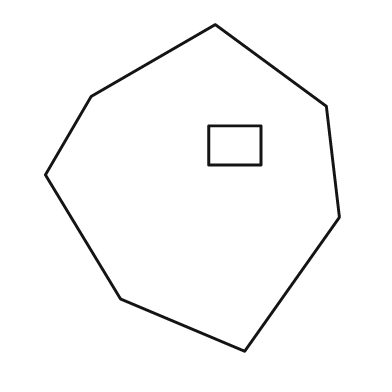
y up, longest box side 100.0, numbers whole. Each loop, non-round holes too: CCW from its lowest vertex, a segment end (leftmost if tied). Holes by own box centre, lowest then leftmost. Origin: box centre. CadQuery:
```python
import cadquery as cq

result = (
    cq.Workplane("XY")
    .moveTo(16.0, -50.0)
    .lineTo(45.0, -9.0)
    .lineTo(41.0, 25.0)
    .lineTo(7.0, 50.0)
    .lineTo(-31.0, 28.0)
    .lineTo(-45.0, 4.0)
    .lineTo(-22.0, -34.0)
    .close()
    .moveTo(5.0, 7.0)
    .lineTo(21.0, 7.0)
    .lineTo(21.0, 19.0)
    .lineTo(5.0, 19.0)
    .close()
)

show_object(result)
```